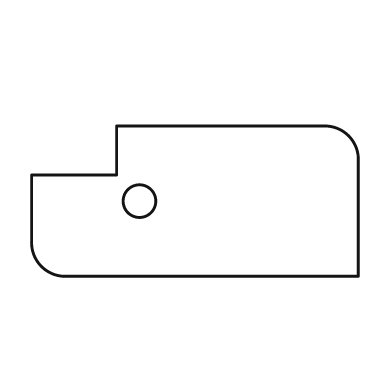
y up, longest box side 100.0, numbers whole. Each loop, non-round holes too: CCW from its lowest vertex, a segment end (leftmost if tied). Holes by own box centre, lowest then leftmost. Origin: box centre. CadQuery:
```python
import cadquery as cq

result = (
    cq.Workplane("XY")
    .moveTo(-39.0, -23.0)
    .lineTo(50.0, -23.0)
    .lineTo(50.0, 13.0)
    .threePointArc((47.0, 20.0), (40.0, 23.0))
    .lineTo(-24.0, 23.0)
    .lineTo(-24.0, 8.0)
    .lineTo(-50.0, 8.0)
    .lineTo(-50.0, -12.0)
    .threePointArc((-47.0, -20.0), (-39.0, -23.0))
    .close()
    .moveTo(-17.0, 0.0)
    .circle(5.0)
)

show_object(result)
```